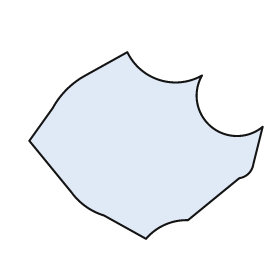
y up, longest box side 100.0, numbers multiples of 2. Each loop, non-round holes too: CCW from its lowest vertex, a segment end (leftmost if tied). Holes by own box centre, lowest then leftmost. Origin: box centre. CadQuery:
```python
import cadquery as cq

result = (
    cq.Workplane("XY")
    .moveTo(0.0, -40.0)
    .threePointArc((8.0, -34.0), (18.0, -32.0))
    .lineTo(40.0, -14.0)
    .threePointArc((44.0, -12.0), (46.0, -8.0))
    .lineTo(50.0, 8.0)
    .threePointArc((28.0, 8.0), (24.0, 30.0))
    .threePointArc((6.0, 28.0), (-8.0, 40.0))
    .lineTo(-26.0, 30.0)
    .threePointArc((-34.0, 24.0), (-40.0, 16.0))
    .lineTo(-50.0, 2.0)
    .lineTo(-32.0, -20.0)
    .threePointArc((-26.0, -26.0), (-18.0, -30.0))
    .close()
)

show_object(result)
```